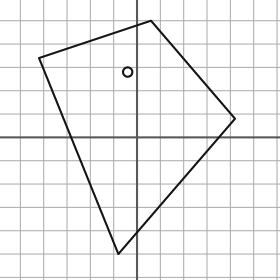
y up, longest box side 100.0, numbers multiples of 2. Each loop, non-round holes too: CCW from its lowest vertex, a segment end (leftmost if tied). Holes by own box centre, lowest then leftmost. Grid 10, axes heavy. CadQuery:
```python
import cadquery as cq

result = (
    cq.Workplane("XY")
    .moveTo(-8.0, -50.0)
    .lineTo(42.0, 8.0)
    .lineTo(6.0, 50.0)
    .lineTo(-42.0, 34.0)
    .close()
    .moveTo(-4.0, 28.0)
    .circle(2.0)
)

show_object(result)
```